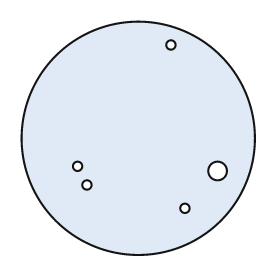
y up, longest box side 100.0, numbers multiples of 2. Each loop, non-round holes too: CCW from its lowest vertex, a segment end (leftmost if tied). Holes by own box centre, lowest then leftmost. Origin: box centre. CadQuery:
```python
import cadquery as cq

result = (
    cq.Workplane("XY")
    .moveTo(0.0, 0.0)
    .circle(50.0)
    .moveTo(20.0, -30.0)
    .circle(2.0)
    .moveTo(-22.0, -20.0)
    .circle(2.0)
    .moveTo(34.0, -14.0)
    .circle(4.0)
    .moveTo(-26.0, -12.0)
    .circle(2.0)
    .moveTo(14.0, 40.0)
    .circle(2.0)
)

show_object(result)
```